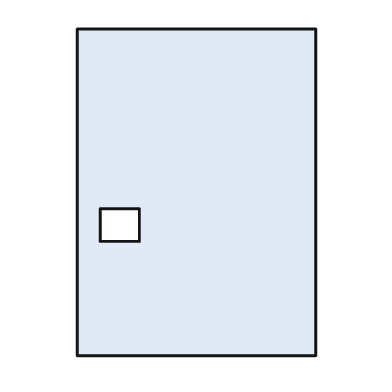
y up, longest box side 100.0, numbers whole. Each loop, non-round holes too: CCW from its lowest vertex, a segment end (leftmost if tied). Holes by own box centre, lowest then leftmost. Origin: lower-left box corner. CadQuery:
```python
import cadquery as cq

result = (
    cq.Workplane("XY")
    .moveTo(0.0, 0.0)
    .lineTo(73.0, 0.0)
    .lineTo(73.0, 100.0)
    .lineTo(0.0, 100.0)
    .close()
    .moveTo(7.0, 35.0)
    .lineTo(19.0, 35.0)
    .lineTo(19.0, 45.0)
    .lineTo(7.0, 45.0)
    .close()
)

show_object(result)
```